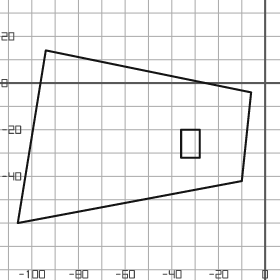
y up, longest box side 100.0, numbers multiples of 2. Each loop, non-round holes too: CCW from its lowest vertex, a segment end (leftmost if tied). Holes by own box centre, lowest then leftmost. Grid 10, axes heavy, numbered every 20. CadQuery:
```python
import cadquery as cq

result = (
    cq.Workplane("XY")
    .moveTo(-106.0, -60.0)
    .lineTo(-10.0, -42.0)
    .lineTo(-6.0, -4.0)
    .lineTo(-94.0, 14.0)
    .close()
    .moveTo(-36.0, -32.0)
    .lineTo(-28.0, -32.0)
    .lineTo(-28.0, -20.0)
    .lineTo(-36.0, -20.0)
    .close()
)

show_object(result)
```